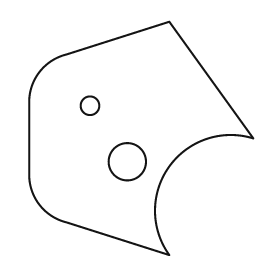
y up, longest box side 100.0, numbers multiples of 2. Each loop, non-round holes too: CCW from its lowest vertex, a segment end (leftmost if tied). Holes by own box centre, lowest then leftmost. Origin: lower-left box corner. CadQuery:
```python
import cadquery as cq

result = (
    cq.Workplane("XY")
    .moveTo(60.0, 0.0)
    .threePointArc((60.0, 38.0), (96.0, 50.0))
    .lineTo(60.0, 100.0)
    .lineTo(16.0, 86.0)
    .threePointArc((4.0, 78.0), (0.0, 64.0))
    .lineTo(0.0, 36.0)
    .threePointArc((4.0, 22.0), (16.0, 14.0))
    .close()
    .moveTo(42.0, 40.0)
    .circle(8.0)
    .moveTo(26.0, 64.0)
    .circle(4.0)
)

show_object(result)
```